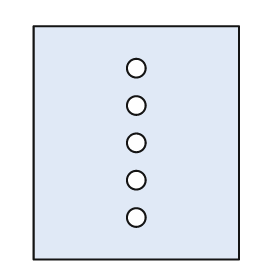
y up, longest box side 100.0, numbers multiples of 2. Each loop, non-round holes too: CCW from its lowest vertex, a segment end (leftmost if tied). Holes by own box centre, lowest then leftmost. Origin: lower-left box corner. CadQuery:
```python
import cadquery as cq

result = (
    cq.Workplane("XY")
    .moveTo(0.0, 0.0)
    .lineTo(88.0, 0.0)
    .lineTo(88.0, 100.0)
    .lineTo(0.0, 100.0)
    .close()
    .moveTo(44.0, 18.0)
    .circle(4.0)
    .moveTo(44.0, 34.0)
    .circle(4.0)
    .moveTo(44.0, 50.0)
    .circle(4.0)
    .moveTo(44.0, 66.0)
    .circle(4.0)
    .moveTo(44.0, 82.0)
    .circle(4.0)
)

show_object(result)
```